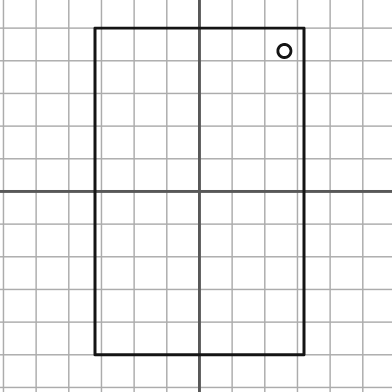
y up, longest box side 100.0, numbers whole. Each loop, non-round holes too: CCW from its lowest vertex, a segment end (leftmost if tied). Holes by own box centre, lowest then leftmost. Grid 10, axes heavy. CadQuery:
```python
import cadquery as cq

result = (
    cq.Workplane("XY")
    .moveTo(-32.0, -50.0)
    .lineTo(32.0, -50.0)
    .lineTo(32.0, 50.0)
    .lineTo(-32.0, 50.0)
    .close()
    .moveTo(26.0, 43.0)
    .circle(2.0)
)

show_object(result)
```